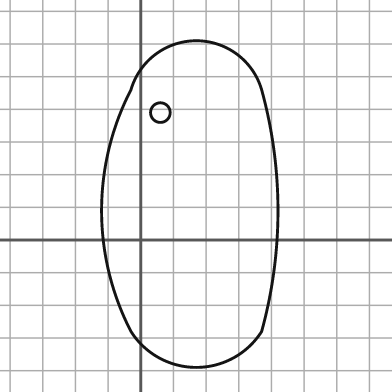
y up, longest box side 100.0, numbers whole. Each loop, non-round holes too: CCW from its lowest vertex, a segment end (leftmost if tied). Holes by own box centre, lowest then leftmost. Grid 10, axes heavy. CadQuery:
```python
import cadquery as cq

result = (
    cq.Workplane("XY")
    .moveTo(-3.0, -28.0)
    .threePointArc((17.0, -39.0), (37.0, -28.0))
    .threePointArc((42.0, 9.0), (37.0, 46.0))
    .threePointArc((17.0, 61.0), (-3.0, 46.0))
    .threePointArc((-12.0, 9.0), (-3.0, -28.0))
    .close()
    .moveTo(6.0, 39.0)
    .circle(3.0)
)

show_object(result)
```